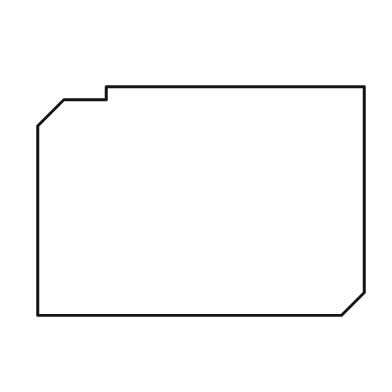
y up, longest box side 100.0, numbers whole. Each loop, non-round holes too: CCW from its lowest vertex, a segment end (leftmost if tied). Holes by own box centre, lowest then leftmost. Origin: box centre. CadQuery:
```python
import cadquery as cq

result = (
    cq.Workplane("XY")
    .moveTo(-50.0, -35.0)
    .lineTo(43.0, -35.0)
    .lineTo(50.0, -28.0)
    .lineTo(50.0, 35.0)
    .lineTo(-29.0, 35.0)
    .lineTo(-29.0, 31.0)
    .lineTo(-42.0, 31.0)
    .lineTo(-50.0, 23.0)
    .close()
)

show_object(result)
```